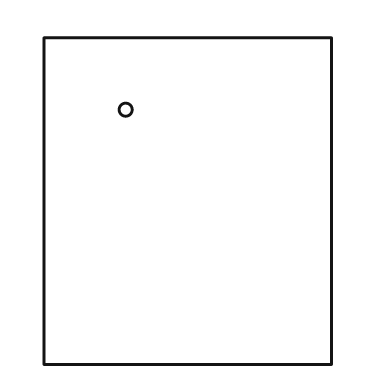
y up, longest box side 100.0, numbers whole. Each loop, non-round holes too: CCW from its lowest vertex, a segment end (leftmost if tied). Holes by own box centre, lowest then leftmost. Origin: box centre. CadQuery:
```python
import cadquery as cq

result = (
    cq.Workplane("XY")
    .moveTo(-44.0, -50.0)
    .lineTo(44.0, -50.0)
    .lineTo(44.0, 50.0)
    .lineTo(-44.0, 50.0)
    .close()
    .moveTo(-19.0, 28.0)
    .circle(2.0)
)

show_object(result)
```